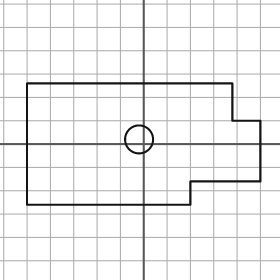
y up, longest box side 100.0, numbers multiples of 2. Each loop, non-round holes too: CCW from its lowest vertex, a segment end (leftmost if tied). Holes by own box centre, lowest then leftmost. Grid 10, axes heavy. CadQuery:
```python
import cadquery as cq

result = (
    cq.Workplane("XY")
    .moveTo(-50.0, -26.0)
    .lineTo(20.0, -26.0)
    .lineTo(20.0, -16.0)
    .lineTo(50.0, -16.0)
    .lineTo(50.0, 10.0)
    .lineTo(38.0, 10.0)
    .lineTo(38.0, 26.0)
    .lineTo(-50.0, 26.0)
    .close()
    .moveTo(-2.0, 2.0)
    .circle(6.0)
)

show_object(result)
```